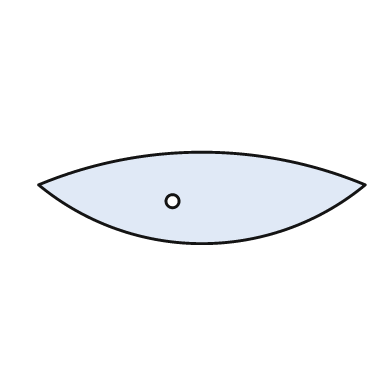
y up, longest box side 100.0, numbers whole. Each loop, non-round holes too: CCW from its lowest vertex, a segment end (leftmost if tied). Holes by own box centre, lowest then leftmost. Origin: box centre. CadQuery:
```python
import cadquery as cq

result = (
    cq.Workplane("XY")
    .moveTo(-50.0, 4.0)
    .threePointArc((0.0, -14.0), (50.0, 4.0))
    .threePointArc((0.0, 14.0), (-50.0, 4.0))
    .close()
    .moveTo(-9.0, -1.0)
    .circle(2.0)
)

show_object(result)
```